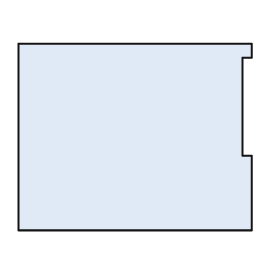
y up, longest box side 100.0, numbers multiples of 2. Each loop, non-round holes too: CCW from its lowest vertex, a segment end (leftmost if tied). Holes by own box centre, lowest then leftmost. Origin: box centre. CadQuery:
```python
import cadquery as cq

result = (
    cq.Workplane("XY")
    .moveTo(-50.0, -40.0)
    .lineTo(50.0, -40.0)
    .lineTo(50.0, -8.0)
    .lineTo(46.0, -8.0)
    .lineTo(46.0, 34.0)
    .lineTo(50.0, 34.0)
    .lineTo(50.0, 40.0)
    .lineTo(-50.0, 40.0)
    .close()
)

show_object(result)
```